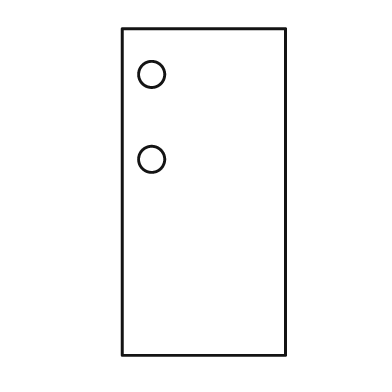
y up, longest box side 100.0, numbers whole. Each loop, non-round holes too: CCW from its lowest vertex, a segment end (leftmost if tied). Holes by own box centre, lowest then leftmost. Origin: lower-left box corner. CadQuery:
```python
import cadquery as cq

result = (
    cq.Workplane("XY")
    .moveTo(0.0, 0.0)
    .lineTo(50.0, 0.0)
    .lineTo(50.0, 100.0)
    .lineTo(0.0, 100.0)
    .close()
    .moveTo(9.0, 60.0)
    .circle(4.0)
    .moveTo(9.0, 86.0)
    .circle(4.0)
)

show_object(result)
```